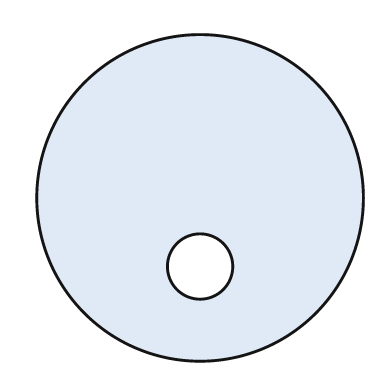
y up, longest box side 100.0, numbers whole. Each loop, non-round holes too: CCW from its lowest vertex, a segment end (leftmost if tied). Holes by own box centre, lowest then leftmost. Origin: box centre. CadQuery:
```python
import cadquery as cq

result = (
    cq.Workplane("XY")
    .moveTo(0.0, 0.0)
    .circle(50.0)
    .moveTo(0.0, -21.0)
    .circle(10.0)
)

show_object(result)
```